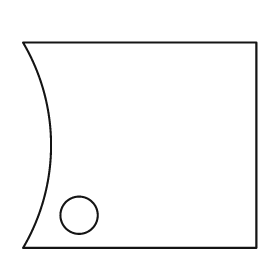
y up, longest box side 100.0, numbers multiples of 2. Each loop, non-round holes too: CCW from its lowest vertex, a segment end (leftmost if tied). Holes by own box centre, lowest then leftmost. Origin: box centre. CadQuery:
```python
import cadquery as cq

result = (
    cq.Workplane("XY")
    .moveTo(-50.0, -44.0)
    .lineTo(50.0, -44.0)
    .lineTo(50.0, 44.0)
    .lineTo(-50.0, 44.0)
    .threePointArc((-38.0, 0.0), (-50.0, -44.0))
    .close()
    .moveTo(-26.0, -30.0)
    .circle(8.0)
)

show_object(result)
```